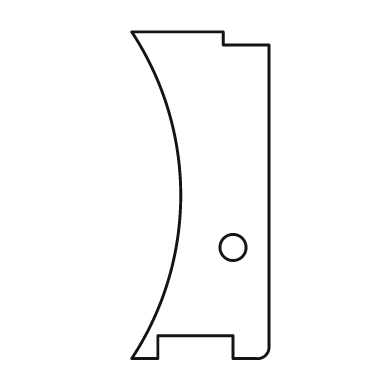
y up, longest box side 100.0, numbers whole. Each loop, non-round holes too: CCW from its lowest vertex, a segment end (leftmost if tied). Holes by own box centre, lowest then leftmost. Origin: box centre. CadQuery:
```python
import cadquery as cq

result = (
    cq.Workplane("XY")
    .moveTo(-21.0, -50.0)
    .lineTo(-13.0, -50.0)
    .lineTo(-13.0, -43.0)
    .lineTo(10.0, -43.0)
    .lineTo(10.0, -50.0)
    .lineTo(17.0, -50.0)
    .threePointArc((20.0, -49.0), (21.0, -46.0))
    .lineTo(21.0, 46.0)
    .lineTo(7.0, 46.0)
    .lineTo(7.0, 50.0)
    .lineTo(-21.0, 50.0)
    .threePointArc((-6.0, 0.0), (-21.0, -50.0))
    .close()
    .moveTo(10.0, -16.0)
    .circle(4.0)
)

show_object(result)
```